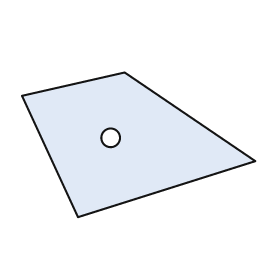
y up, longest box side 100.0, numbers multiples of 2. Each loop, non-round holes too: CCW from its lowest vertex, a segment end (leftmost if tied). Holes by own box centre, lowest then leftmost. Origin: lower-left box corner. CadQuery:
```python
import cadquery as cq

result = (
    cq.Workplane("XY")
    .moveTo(24.0, 0.0)
    .lineTo(100.0, 24.0)
    .lineTo(44.0, 62.0)
    .lineTo(0.0, 52.0)
    .close()
    .moveTo(38.0, 34.0)
    .circle(4.0)
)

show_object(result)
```